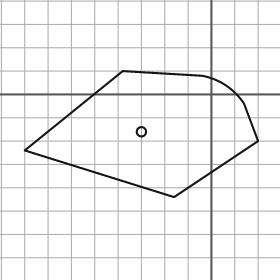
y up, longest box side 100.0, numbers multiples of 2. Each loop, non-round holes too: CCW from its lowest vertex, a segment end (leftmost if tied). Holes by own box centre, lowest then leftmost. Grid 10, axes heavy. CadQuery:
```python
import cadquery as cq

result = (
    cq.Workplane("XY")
    .moveTo(-16.0, -44.0)
    .lineTo(20.0, -20.0)
    .lineTo(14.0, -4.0)
    .threePointArc((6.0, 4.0), (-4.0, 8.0))
    .lineTo(-38.0, 10.0)
    .lineTo(-80.0, -24.0)
    .close()
    .moveTo(-30.0, -16.0)
    .circle(2.0)
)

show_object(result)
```